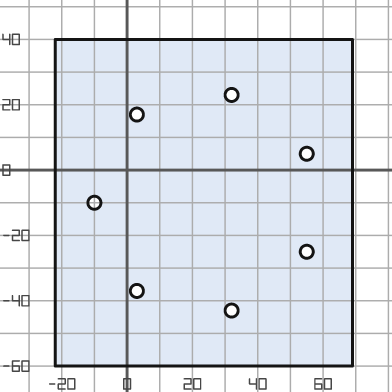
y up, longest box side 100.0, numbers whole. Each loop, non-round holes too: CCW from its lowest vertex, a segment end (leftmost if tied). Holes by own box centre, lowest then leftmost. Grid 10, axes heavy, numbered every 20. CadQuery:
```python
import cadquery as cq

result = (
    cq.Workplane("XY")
    .moveTo(-22.0, -60.0)
    .lineTo(69.0, -60.0)
    .lineTo(69.0, 40.0)
    .lineTo(-22.0, 40.0)
    .close()
    .moveTo(32.0, -43.0)
    .circle(2.0)
    .moveTo(3.0, -37.0)
    .circle(2.0)
    .moveTo(55.0, -25.0)
    .circle(2.0)
    .moveTo(-10.0, -10.0)
    .circle(2.0)
    .moveTo(55.0, 5.0)
    .circle(2.0)
    .moveTo(3.0, 17.0)
    .circle(2.0)
    .moveTo(32.0, 23.0)
    .circle(2.0)
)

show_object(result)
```